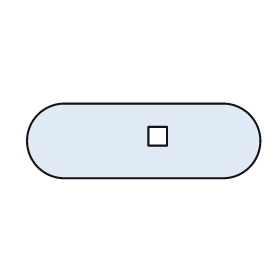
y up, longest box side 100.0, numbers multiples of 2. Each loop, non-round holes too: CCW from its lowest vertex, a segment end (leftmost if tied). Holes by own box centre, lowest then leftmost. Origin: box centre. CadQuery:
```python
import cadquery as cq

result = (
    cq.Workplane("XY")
    .moveTo(-34.0, -16.0)
    .lineTo(34.0, -16.0)
    .threePointArc((50.0, 0.0), (34.0, 16.0))
    .lineTo(-34.0, 16.0)
    .threePointArc((-50.0, 0.0), (-34.0, -16.0))
    .close()
    .moveTo(2.0, -2.0)
    .lineTo(10.0, -2.0)
    .lineTo(10.0, 6.0)
    .lineTo(2.0, 6.0)
    .close()
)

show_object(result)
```